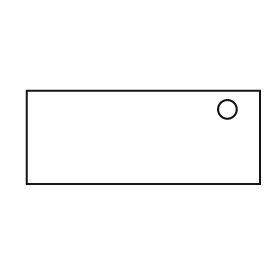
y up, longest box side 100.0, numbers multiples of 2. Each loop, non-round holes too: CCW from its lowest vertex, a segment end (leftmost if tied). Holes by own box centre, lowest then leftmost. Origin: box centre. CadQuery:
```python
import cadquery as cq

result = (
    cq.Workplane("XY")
    .moveTo(-50.0, -20.0)
    .lineTo(50.0, -20.0)
    .lineTo(50.0, 20.0)
    .lineTo(-50.0, 20.0)
    .close()
    .moveTo(36.0, 12.0)
    .circle(4.0)
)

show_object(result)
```